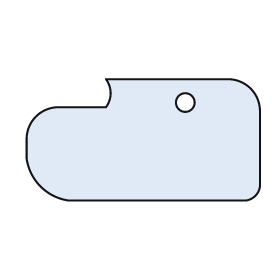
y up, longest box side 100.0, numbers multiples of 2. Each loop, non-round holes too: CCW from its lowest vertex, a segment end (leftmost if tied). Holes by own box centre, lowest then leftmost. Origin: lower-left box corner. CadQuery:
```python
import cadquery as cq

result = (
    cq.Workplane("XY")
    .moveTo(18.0, 0.0)
    .lineTo(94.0, 0.0)
    .threePointArc((98.0, 2.0), (100.0, 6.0))
    .lineTo(100.0, 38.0)
    .threePointArc((96.0, 48.0), (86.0, 52.0))
    .lineTo(34.0, 52.0)
    .threePointArc((36.0, 46.0), (34.0, 40.0))
    .lineTo(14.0, 40.0)
    .threePointArc((4.0, 36.0), (0.0, 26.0))
    .lineTo(0.0, 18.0)
    .threePointArc((6.0, 6.0), (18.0, 0.0))
    .close()
    .moveTo(68.0, 42.0)
    .circle(4.0)
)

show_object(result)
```